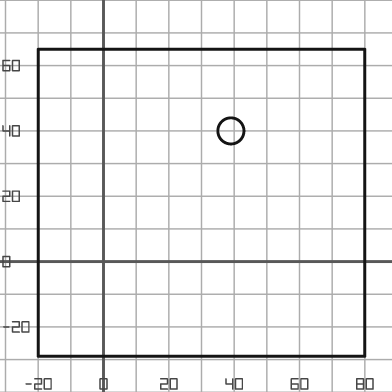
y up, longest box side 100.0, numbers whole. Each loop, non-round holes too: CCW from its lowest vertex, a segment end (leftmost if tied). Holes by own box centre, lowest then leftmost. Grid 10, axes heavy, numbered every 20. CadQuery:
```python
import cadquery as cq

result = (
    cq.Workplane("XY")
    .moveTo(-20.0, -29.0)
    .lineTo(80.0, -29.0)
    .lineTo(80.0, 65.0)
    .lineTo(-20.0, 65.0)
    .close()
    .moveTo(39.0, 40.0)
    .circle(4.0)
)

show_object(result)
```